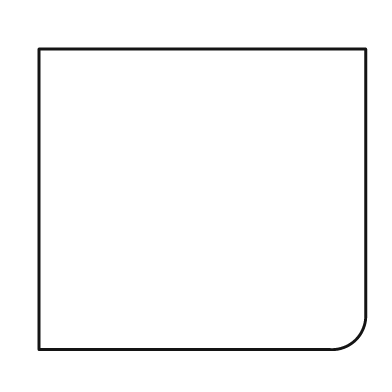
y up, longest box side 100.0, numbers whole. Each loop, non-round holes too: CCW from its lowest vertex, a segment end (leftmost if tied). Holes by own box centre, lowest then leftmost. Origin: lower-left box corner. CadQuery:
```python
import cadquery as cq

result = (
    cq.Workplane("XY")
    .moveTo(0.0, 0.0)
    .lineTo(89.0, 0.0)
    .threePointArc((97.0, 3.0), (100.0, 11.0))
    .lineTo(100.0, 92.0)
    .lineTo(0.0, 92.0)
    .close()
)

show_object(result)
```